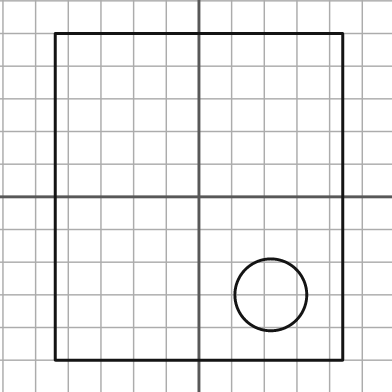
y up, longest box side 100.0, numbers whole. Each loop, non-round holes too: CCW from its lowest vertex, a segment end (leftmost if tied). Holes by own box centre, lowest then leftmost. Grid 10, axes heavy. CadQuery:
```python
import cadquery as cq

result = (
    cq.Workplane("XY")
    .moveTo(-44.0, -50.0)
    .lineTo(44.0, -50.0)
    .lineTo(44.0, 50.0)
    .lineTo(-44.0, 50.0)
    .close()
    .moveTo(22.0, -30.0)
    .circle(11.0)
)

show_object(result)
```